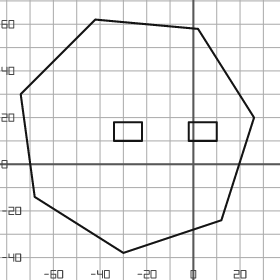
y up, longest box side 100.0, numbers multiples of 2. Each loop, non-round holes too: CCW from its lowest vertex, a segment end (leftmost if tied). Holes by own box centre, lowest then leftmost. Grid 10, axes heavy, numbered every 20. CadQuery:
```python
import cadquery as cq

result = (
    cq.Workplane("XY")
    .moveTo(-30.0, -38.0)
    .lineTo(12.0, -24.0)
    .lineTo(26.0, 20.0)
    .lineTo(2.0, 58.0)
    .lineTo(-42.0, 62.0)
    .lineTo(-74.0, 30.0)
    .lineTo(-68.0, -14.0)
    .close()
    .moveTo(-34.0, 10.0)
    .lineTo(-22.0, 10.0)
    .lineTo(-22.0, 18.0)
    .lineTo(-34.0, 18.0)
    .close()
    .moveTo(-2.0, 10.0)
    .lineTo(10.0, 10.0)
    .lineTo(10.0, 18.0)
    .lineTo(-2.0, 18.0)
    .close()
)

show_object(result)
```